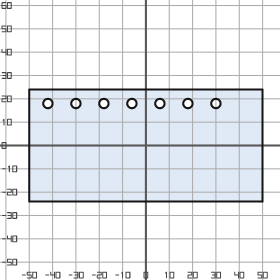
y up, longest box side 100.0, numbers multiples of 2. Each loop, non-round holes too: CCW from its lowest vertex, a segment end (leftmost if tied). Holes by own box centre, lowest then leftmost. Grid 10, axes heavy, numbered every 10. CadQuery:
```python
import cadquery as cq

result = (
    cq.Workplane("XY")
    .moveTo(-50.0, -24.0)
    .lineTo(50.0, -24.0)
    .lineTo(50.0, 24.0)
    .lineTo(-50.0, 24.0)
    .close()
    .moveTo(-42.0, 18.0)
    .circle(2.0)
    .moveTo(-30.0, 18.0)
    .circle(2.0)
    .moveTo(-18.0, 18.0)
    .circle(2.0)
    .moveTo(-6.0, 18.0)
    .circle(2.0)
    .moveTo(6.0, 18.0)
    .circle(2.0)
    .moveTo(18.0, 18.0)
    .circle(2.0)
    .moveTo(30.0, 18.0)
    .circle(2.0)
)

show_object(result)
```